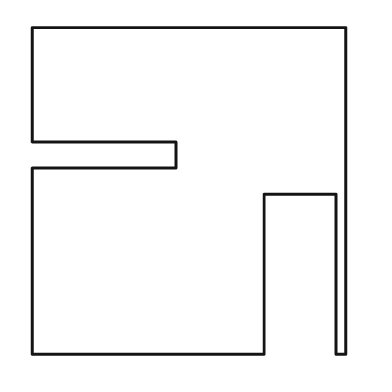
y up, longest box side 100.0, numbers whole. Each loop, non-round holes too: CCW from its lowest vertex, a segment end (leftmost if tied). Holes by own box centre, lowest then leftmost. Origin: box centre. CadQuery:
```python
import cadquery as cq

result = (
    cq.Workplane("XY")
    .moveTo(-48.0, -50.0)
    .lineTo(23.0, -50.0)
    .lineTo(23.0, -1.0)
    .lineTo(45.0, -1.0)
    .lineTo(45.0, -50.0)
    .lineTo(48.0, -50.0)
    .lineTo(48.0, 50.0)
    .lineTo(-48.0, 50.0)
    .lineTo(-48.0, 15.0)
    .lineTo(-4.0, 15.0)
    .lineTo(-4.0, 7.0)
    .lineTo(-48.0, 7.0)
    .close()
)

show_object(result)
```